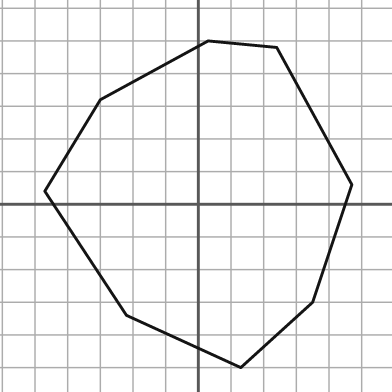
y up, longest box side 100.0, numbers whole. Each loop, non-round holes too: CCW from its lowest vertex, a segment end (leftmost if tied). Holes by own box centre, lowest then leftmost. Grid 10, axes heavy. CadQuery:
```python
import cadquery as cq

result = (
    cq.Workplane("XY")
    .moveTo(13.0, -50.0)
    .lineTo(35.0, -30.0)
    .lineTo(47.0, 6.0)
    .lineTo(24.0, 48.0)
    .lineTo(3.0, 50.0)
    .lineTo(-30.0, 32.0)
    .lineTo(-47.0, 4.0)
    .lineTo(-22.0, -34.0)
    .close()
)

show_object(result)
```